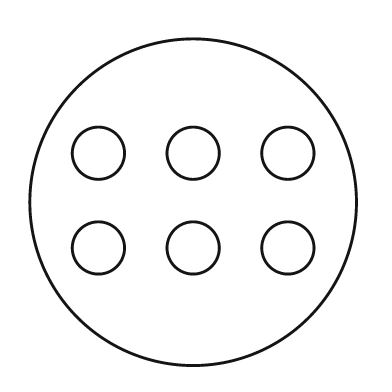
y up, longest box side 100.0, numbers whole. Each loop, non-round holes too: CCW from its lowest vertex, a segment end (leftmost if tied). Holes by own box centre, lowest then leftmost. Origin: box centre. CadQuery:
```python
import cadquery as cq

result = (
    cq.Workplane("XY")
    .moveTo(0.0, 0.0)
    .circle(50.0)
    .moveTo(-29.0, -14.0)
    .circle(8.0)
    .moveTo(0.0, -14.0)
    .circle(8.0)
    .moveTo(29.0, -14.0)
    .circle(8.0)
    .moveTo(-29.0, 15.0)
    .circle(8.0)
    .moveTo(0.0, 15.0)
    .circle(8.0)
    .moveTo(29.0, 15.0)
    .circle(8.0)
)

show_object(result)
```